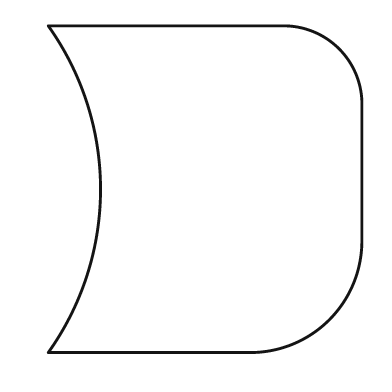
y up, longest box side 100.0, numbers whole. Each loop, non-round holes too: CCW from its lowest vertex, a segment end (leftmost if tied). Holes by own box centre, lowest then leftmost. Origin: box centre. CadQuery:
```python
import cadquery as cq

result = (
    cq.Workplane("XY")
    .moveTo(-48.0, -50.0)
    .lineTo(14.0, -50.0)
    .threePointArc((38.0, -40.0), (48.0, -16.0))
    .lineTo(48.0, 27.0)
    .threePointArc((41.0, 43.0), (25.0, 50.0))
    .lineTo(-48.0, 50.0)
    .threePointArc((-32.0, 0.0), (-48.0, -50.0))
    .close()
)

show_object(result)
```